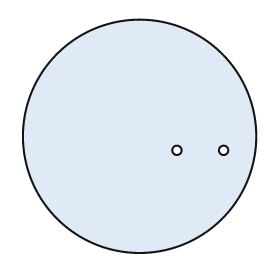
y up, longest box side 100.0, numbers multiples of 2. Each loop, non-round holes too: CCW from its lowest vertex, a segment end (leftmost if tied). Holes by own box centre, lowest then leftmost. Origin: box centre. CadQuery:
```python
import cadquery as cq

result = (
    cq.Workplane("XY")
    .moveTo(0.0, 0.0)
    .circle(50.0)
    .moveTo(16.0, -6.0)
    .circle(2.0)
    .moveTo(36.0, -6.0)
    .circle(2.0)
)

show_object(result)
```